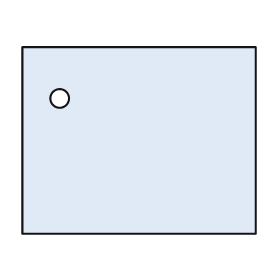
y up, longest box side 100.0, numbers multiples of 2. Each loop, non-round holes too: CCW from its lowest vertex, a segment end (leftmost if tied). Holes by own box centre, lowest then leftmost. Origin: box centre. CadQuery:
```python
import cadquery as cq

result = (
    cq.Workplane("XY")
    .moveTo(-50.0, -40.0)
    .lineTo(50.0, -40.0)
    .lineTo(50.0, 40.0)
    .lineTo(-50.0, 40.0)
    .close()
    .moveTo(-34.0, 18.0)
    .circle(4.0)
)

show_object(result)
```